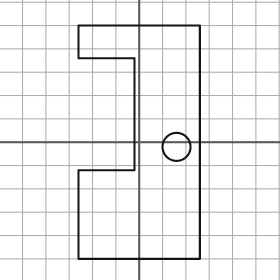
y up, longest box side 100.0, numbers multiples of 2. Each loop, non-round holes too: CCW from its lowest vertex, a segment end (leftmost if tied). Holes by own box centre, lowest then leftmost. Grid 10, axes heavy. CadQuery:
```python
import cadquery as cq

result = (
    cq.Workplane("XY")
    .moveTo(-26.0, -50.0)
    .lineTo(26.0, -50.0)
    .lineTo(26.0, 50.0)
    .lineTo(-26.0, 50.0)
    .lineTo(-26.0, 36.0)
    .lineTo(-2.0, 36.0)
    .lineTo(-2.0, -12.0)
    .lineTo(-26.0, -12.0)
    .close()
    .moveTo(16.0, -2.0)
    .circle(6.0)
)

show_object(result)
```